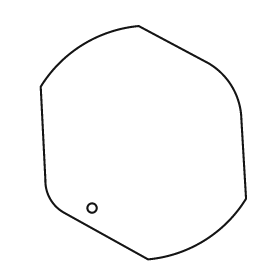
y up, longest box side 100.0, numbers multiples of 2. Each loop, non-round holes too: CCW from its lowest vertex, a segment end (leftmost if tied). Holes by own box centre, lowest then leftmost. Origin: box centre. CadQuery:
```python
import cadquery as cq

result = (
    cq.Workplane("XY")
    .moveTo(2.0, -50.0)
    .threePointArc((26.0, -42.0), (44.0, -24.0))
    .lineTo(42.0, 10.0)
    .threePointArc((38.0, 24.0), (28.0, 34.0))
    .lineTo(-2.0, 50.0)
    .threePointArc((-26.0, 42.0), (-44.0, 24.0))
    .lineTo(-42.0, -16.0)
    .threePointArc((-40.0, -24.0), (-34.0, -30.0))
    .close()
    .moveTo(-22.0, -28.0)
    .circle(2.0)
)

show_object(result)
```